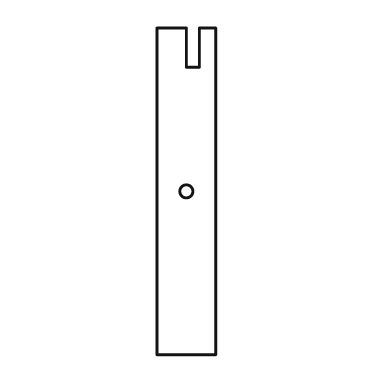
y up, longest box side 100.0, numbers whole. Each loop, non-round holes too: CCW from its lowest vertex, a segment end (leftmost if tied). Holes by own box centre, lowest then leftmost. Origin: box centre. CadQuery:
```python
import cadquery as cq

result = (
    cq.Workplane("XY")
    .moveTo(-9.0, -50.0)
    .lineTo(9.0, -50.0)
    .lineTo(9.0, 50.0)
    .lineTo(4.0, 50.0)
    .lineTo(4.0, 38.0)
    .lineTo(0.0, 38.0)
    .lineTo(0.0, 50.0)
    .lineTo(-9.0, 50.0)
    .close()
    .moveTo(0.0, 0.0)
    .circle(2.0)
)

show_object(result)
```